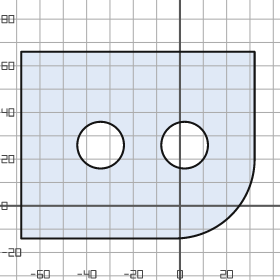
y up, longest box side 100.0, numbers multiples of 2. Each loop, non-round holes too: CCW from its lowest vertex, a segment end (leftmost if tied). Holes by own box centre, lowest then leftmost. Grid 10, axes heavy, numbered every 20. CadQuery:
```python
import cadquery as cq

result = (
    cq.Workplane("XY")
    .moveTo(-68.0, -14.0)
    .lineTo(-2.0, -14.0)
    .threePointArc((22.0, -4.0), (32.0, 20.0))
    .lineTo(32.0, 66.0)
    .lineTo(-68.0, 66.0)
    .close()
    .moveTo(-34.0, 26.0)
    .circle(10.0)
    .moveTo(2.0, 26.0)
    .circle(10.0)
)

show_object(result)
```